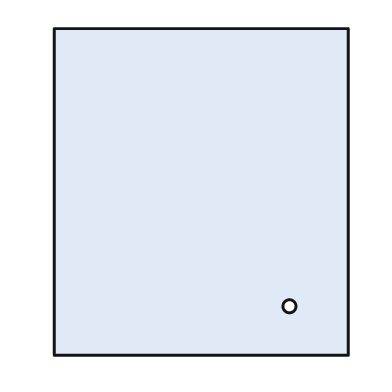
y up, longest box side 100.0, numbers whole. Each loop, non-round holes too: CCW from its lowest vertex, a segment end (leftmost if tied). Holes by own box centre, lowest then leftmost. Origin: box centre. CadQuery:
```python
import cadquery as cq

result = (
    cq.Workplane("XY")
    .moveTo(-45.0, -50.0)
    .lineTo(45.0, -50.0)
    .lineTo(45.0, 50.0)
    .lineTo(-45.0, 50.0)
    .close()
    .moveTo(27.0, -35.0)
    .circle(2.0)
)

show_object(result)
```